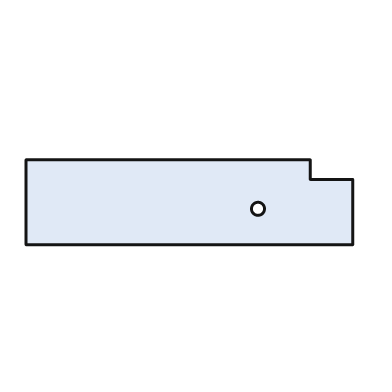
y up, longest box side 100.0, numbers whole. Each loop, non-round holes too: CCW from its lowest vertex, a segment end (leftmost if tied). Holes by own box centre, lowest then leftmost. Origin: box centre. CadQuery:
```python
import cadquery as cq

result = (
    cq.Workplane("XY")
    .moveTo(-50.0, -13.0)
    .lineTo(50.0, -13.0)
    .lineTo(50.0, 7.0)
    .lineTo(37.0, 7.0)
    .lineTo(37.0, 13.0)
    .lineTo(-50.0, 13.0)
    .close()
    .moveTo(21.0, -2.0)
    .circle(2.0)
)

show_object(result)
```